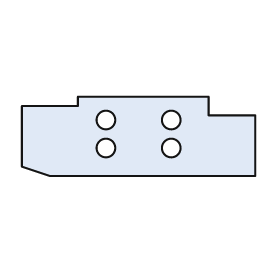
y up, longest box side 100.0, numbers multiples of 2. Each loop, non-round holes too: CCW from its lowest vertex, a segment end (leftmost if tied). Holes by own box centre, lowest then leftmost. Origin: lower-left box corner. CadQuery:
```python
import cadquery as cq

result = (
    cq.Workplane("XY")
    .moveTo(12.0, 0.0)
    .lineTo(100.0, 0.0)
    .lineTo(100.0, 26.0)
    .lineTo(80.0, 26.0)
    .lineTo(80.0, 34.0)
    .lineTo(24.0, 34.0)
    .lineTo(24.0, 30.0)
    .lineTo(0.0, 30.0)
    .lineTo(0.0, 4.0)
    .close()
    .moveTo(36.0, 12.0)
    .circle(4.0)
    .moveTo(64.0, 12.0)
    .circle(4.0)
    .moveTo(36.0, 24.0)
    .circle(4.0)
    .moveTo(64.0, 24.0)
    .circle(4.0)
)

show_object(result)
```